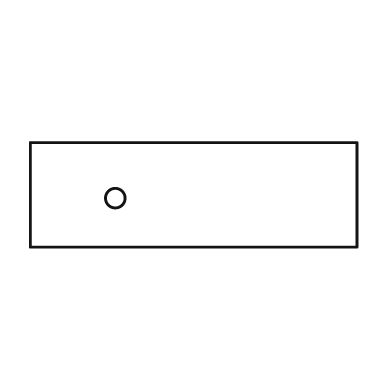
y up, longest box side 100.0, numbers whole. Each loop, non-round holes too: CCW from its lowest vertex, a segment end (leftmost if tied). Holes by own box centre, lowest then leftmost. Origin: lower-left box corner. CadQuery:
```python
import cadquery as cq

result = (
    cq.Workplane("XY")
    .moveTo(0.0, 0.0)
    .lineTo(100.0, 0.0)
    .lineTo(100.0, 32.0)
    .lineTo(0.0, 32.0)
    .close()
    .moveTo(26.0, 15.0)
    .circle(3.0)
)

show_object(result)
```